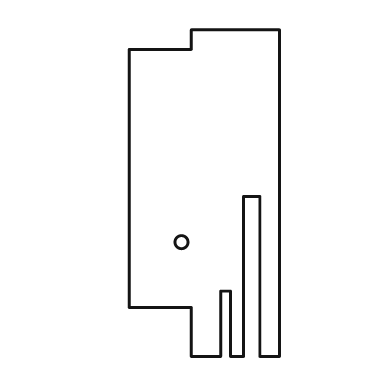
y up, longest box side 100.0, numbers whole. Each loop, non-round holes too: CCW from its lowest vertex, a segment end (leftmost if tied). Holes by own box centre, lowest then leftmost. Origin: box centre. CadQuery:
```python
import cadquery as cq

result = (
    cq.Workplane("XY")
    .moveTo(-4.0, -50.0)
    .lineTo(5.0, -50.0)
    .lineTo(5.0, -30.0)
    .lineTo(8.0, -30.0)
    .lineTo(8.0, -50.0)
    .lineTo(12.0, -50.0)
    .lineTo(12.0, -1.0)
    .lineTo(17.0, -1.0)
    .lineTo(17.0, -50.0)
    .lineTo(23.0, -50.0)
    .lineTo(23.0, 50.0)
    .lineTo(-4.0, 50.0)
    .lineTo(-4.0, 44.0)
    .lineTo(-23.0, 44.0)
    .lineTo(-23.0, -35.0)
    .lineTo(-4.0, -35.0)
    .close()
    .moveTo(-7.0, -15.0)
    .circle(2.0)
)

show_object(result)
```